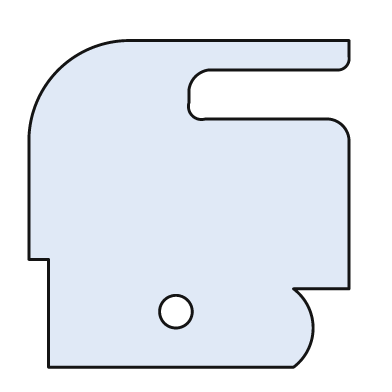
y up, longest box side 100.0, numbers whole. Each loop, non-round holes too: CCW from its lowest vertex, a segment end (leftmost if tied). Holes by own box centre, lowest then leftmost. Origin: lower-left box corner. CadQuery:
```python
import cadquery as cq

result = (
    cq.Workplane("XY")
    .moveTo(6.0, 0.0)
    .lineTo(81.0, 0.0)
    .threePointArc((87.0, 12.0), (81.0, 24.0))
    .lineTo(98.0, 24.0)
    .lineTo(98.0, 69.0)
    .threePointArc((96.0, 74.0), (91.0, 76.0))
    .lineTo(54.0, 76.0)
    .threePointArc((50.0, 77.0), (49.0, 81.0))
    .lineTo(49.0, 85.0)
    .threePointArc((51.0, 89.0), (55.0, 91.0))
    .lineTo(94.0, 91.0)
    .threePointArc((97.0, 92.0), (98.0, 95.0))
    .lineTo(98.0, 100.0)
    .lineTo(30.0, 100.0)
    .threePointArc((9.0, 91.0), (0.0, 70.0))
    .lineTo(0.0, 33.0)
    .lineTo(6.0, 33.0)
    .close()
    .moveTo(45.0, 17.0)
    .circle(5.0)
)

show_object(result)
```